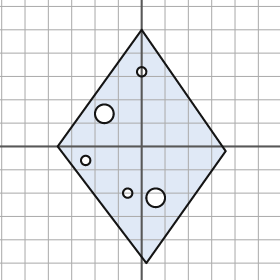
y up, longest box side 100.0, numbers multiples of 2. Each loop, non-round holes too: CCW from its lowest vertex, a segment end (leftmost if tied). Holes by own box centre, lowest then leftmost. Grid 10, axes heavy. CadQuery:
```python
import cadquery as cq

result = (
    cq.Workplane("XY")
    .moveTo(2.0, -50.0)
    .lineTo(36.0, -2.0)
    .lineTo(0.0, 50.0)
    .lineTo(-36.0, 0.0)
    .close()
    .moveTo(6.0, -22.0)
    .circle(4.0)
    .moveTo(-6.0, -20.0)
    .circle(2.0)
    .moveTo(-24.0, -6.0)
    .circle(2.0)
    .moveTo(-16.0, 14.0)
    .circle(4.0)
    .moveTo(0.0, 32.0)
    .circle(2.0)
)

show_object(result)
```